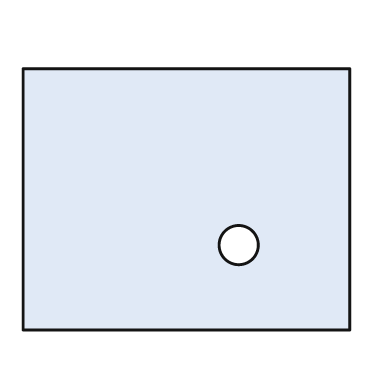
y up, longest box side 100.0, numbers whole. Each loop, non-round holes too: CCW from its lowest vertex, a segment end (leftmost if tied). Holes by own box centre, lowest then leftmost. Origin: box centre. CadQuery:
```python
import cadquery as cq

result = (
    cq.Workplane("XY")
    .moveTo(-50.0, -40.0)
    .lineTo(50.0, -40.0)
    .lineTo(50.0, 40.0)
    .lineTo(-50.0, 40.0)
    .close()
    .moveTo(16.0, -14.0)
    .circle(6.0)
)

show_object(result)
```